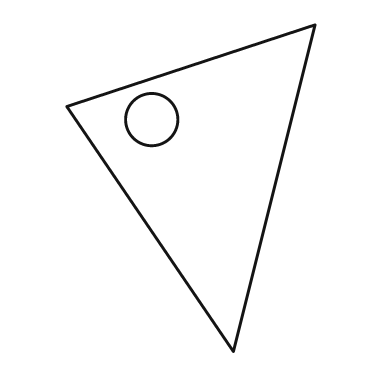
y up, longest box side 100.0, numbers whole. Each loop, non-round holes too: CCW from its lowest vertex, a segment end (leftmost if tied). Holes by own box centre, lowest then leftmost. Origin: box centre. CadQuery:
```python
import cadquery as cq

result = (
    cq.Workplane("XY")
    .moveTo(13.0, -50.0)
    .lineTo(38.0, 50.0)
    .lineTo(-38.0, 25.0)
    .close()
    .moveTo(-12.0, 21.0)
    .circle(8.0)
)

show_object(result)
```